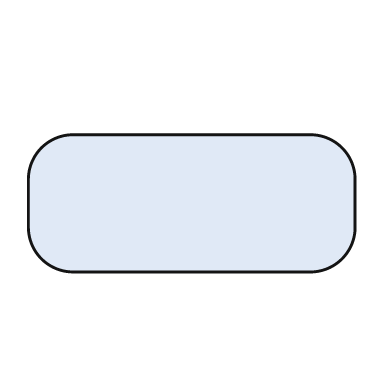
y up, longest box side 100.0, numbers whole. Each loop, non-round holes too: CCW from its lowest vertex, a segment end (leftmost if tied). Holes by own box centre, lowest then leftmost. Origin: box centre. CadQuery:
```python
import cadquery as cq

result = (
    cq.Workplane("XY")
    .moveTo(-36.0, -21.0)
    .lineTo(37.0, -21.0)
    .threePointArc((46.0, -17.0), (50.0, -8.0))
    .lineTo(50.0, 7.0)
    .threePointArc((46.0, 17.0), (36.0, 21.0))
    .lineTo(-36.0, 21.0)
    .threePointArc((-46.0, 17.0), (-50.0, 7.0))
    .lineTo(-50.0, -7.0)
    .threePointArc((-46.0, -17.0), (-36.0, -21.0))
    .close()
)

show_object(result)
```